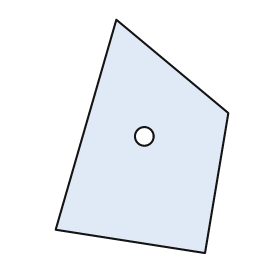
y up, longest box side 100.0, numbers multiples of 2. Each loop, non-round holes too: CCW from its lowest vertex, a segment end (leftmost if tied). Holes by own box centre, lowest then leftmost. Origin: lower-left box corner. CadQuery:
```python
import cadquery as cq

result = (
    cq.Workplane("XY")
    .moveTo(64.0, 0.0)
    .lineTo(74.0, 60.0)
    .lineTo(26.0, 100.0)
    .lineTo(0.0, 10.0)
    .close()
    .moveTo(38.0, 50.0)
    .circle(4.0)
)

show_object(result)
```